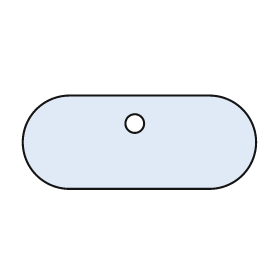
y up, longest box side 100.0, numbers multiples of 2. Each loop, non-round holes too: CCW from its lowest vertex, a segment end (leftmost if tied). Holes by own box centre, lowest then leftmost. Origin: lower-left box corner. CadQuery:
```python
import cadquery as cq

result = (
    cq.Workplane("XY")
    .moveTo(20.0, 0.0)
    .lineTo(80.0, 0.0)
    .threePointArc((100.0, 20.0), (80.0, 40.0))
    .lineTo(20.0, 40.0)
    .threePointArc((0.0, 20.0), (20.0, 0.0))
    .close()
    .moveTo(48.0, 28.0)
    .circle(4.0)
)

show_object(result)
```